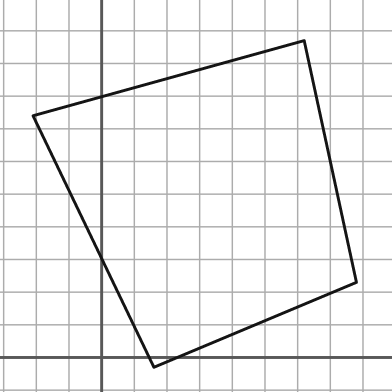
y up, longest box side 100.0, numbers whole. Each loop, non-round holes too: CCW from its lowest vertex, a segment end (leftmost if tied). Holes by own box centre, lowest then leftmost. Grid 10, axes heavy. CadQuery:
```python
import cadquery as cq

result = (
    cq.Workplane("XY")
    .moveTo(16.0, -3.0)
    .lineTo(78.0, 23.0)
    .lineTo(62.0, 97.0)
    .lineTo(-21.0, 74.0)
    .close()
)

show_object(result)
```